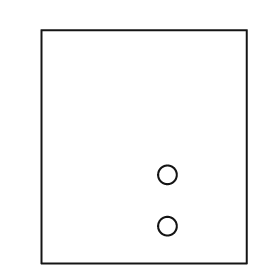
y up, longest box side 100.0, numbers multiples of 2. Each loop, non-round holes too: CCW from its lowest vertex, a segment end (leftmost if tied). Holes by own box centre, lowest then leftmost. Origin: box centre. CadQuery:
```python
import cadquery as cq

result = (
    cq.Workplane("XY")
    .moveTo(-44.0, -50.0)
    .lineTo(44.0, -50.0)
    .lineTo(44.0, 50.0)
    .lineTo(-44.0, 50.0)
    .close()
    .moveTo(10.0, -34.0)
    .circle(4.0)
    .moveTo(10.0, -12.0)
    .circle(4.0)
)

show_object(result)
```